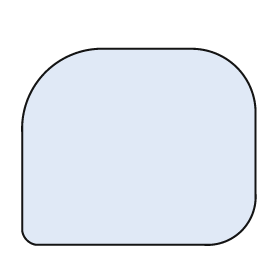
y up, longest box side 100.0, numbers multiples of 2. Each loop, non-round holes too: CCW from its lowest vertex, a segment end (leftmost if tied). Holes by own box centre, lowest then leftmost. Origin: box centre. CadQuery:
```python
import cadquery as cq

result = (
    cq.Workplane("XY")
    .moveTo(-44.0, -42.0)
    .lineTo(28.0, -42.0)
    .threePointArc((44.0, -36.0), (50.0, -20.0))
    .lineTo(50.0, 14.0)
    .threePointArc((42.0, 34.0), (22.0, 42.0))
    .lineTo(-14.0, 42.0)
    .threePointArc((-40.0, 32.0), (-50.0, 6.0))
    .lineTo(-50.0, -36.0)
    .threePointArc((-48.0, -40.0), (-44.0, -42.0))
    .close()
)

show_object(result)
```